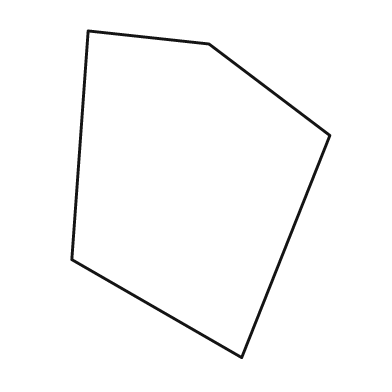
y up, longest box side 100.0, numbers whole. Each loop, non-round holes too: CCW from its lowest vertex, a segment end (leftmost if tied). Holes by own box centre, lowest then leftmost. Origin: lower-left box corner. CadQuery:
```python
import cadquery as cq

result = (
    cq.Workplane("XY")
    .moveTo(52.0, 0.0)
    .lineTo(79.0, 68.0)
    .lineTo(42.0, 96.0)
    .lineTo(5.0, 100.0)
    .lineTo(0.0, 30.0)
    .close()
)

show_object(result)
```